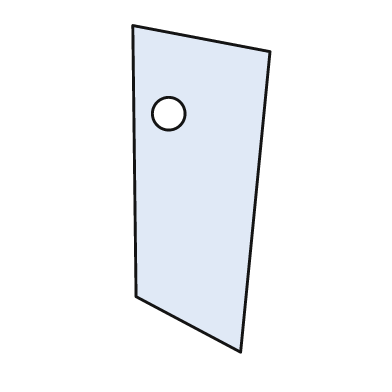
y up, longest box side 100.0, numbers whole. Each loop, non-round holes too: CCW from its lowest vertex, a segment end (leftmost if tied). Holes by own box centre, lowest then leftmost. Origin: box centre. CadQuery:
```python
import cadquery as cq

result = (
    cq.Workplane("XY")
    .moveTo(12.0, -50.0)
    .lineTo(21.0, 42.0)
    .lineTo(-21.0, 50.0)
    .lineTo(-20.0, -33.0)
    .close()
    .moveTo(-10.0, 23.0)
    .circle(5.0)
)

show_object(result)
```